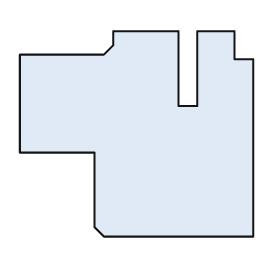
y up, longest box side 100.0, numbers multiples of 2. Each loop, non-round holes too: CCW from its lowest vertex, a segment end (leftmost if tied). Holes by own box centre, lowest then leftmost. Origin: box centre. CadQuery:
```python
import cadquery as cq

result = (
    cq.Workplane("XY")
    .moveTo(-14.0, -44.0)
    .lineTo(50.0, -44.0)
    .lineTo(50.0, 32.0)
    .lineTo(42.0, 32.0)
    .lineTo(42.0, 44.0)
    .lineTo(26.0, 44.0)
    .lineTo(26.0, 12.0)
    .lineTo(18.0, 12.0)
    .lineTo(18.0, 44.0)
    .lineTo(-10.0, 44.0)
    .lineTo(-10.0, 38.0)
    .lineTo(-14.0, 34.0)
    .lineTo(-50.0, 34.0)
    .lineTo(-50.0, -8.0)
    .lineTo(-18.0, -8.0)
    .lineTo(-18.0, -40.0)
    .close()
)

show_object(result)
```